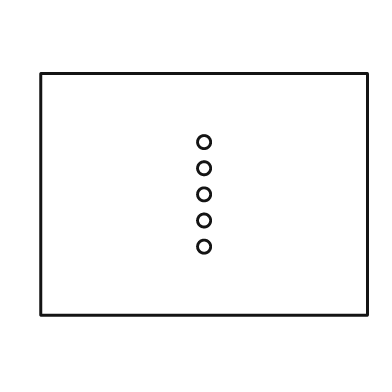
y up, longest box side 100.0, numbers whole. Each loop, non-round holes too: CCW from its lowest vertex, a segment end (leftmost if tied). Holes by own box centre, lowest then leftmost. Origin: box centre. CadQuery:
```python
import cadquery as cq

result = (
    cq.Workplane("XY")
    .moveTo(-50.0, -37.0)
    .lineTo(50.0, -37.0)
    .lineTo(50.0, 37.0)
    .lineTo(-50.0, 37.0)
    .close()
    .moveTo(0.0, -16.0)
    .circle(2.0)
    .moveTo(0.0, -8.0)
    .circle(2.0)
    .moveTo(0.0, 0.0)
    .circle(2.0)
    .moveTo(0.0, 8.0)
    .circle(2.0)
    .moveTo(0.0, 16.0)
    .circle(2.0)
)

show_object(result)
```